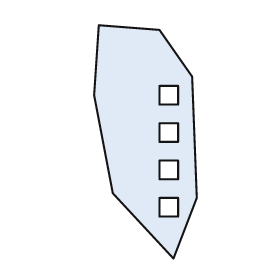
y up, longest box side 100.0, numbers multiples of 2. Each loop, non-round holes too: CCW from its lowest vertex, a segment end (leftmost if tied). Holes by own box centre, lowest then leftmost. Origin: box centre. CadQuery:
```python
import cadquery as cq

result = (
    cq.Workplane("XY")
    .moveTo(12.0, -50.0)
    .lineTo(22.0, -24.0)
    .lineTo(20.0, 28.0)
    .lineTo(6.0, 48.0)
    .lineTo(-20.0, 50.0)
    .lineTo(-22.0, 20.0)
    .lineTo(-14.0, -22.0)
    .close()
    .moveTo(6.0, -32.0)
    .lineTo(14.0, -32.0)
    .lineTo(14.0, -24.0)
    .lineTo(6.0, -24.0)
    .close()
    .moveTo(6.0, -16.0)
    .lineTo(14.0, -16.0)
    .lineTo(14.0, -8.0)
    .lineTo(6.0, -8.0)
    .close()
    .moveTo(6.0, 0.0)
    .lineTo(14.0, 0.0)
    .lineTo(14.0, 8.0)
    .lineTo(6.0, 8.0)
    .close()
    .moveTo(6.0, 16.0)
    .lineTo(14.0, 16.0)
    .lineTo(14.0, 24.0)
    .lineTo(6.0, 24.0)
    .close()
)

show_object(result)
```